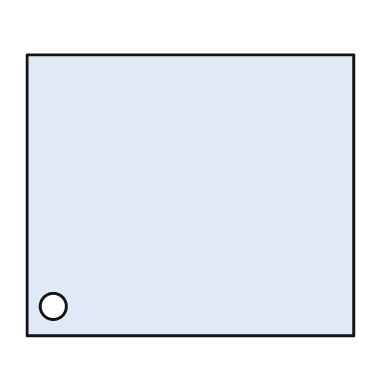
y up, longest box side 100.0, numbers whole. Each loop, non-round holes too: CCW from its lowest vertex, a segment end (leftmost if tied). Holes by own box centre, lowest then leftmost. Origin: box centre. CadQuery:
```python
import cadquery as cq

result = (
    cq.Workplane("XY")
    .moveTo(-50.0, -43.0)
    .lineTo(50.0, -43.0)
    .lineTo(50.0, 43.0)
    .lineTo(-50.0, 43.0)
    .close()
    .moveTo(-42.0, -34.0)
    .circle(4.0)
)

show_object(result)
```